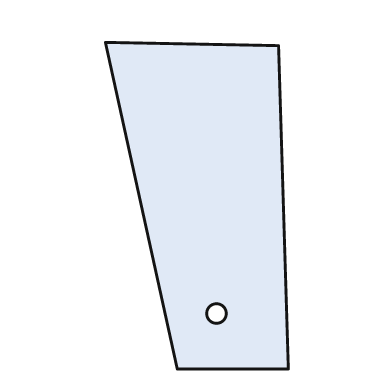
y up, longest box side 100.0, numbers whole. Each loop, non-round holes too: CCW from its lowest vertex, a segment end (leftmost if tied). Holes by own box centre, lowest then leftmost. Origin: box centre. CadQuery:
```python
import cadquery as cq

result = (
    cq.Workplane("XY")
    .moveTo(-6.0, -50.0)
    .lineTo(28.0, -50.0)
    .lineTo(25.0, 49.0)
    .lineTo(-28.0, 50.0)
    .close()
    .moveTo(6.0, -33.0)
    .circle(3.0)
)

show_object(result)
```